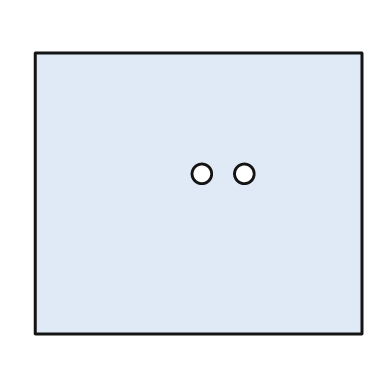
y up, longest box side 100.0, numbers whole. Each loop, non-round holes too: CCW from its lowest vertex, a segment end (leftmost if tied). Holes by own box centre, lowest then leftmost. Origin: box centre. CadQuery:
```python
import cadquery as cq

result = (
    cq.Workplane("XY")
    .moveTo(-50.0, -43.0)
    .lineTo(50.0, -43.0)
    .lineTo(50.0, 43.0)
    .lineTo(-50.0, 43.0)
    .close()
    .moveTo(1.0, 6.0)
    .circle(3.0)
    .moveTo(14.0, 6.0)
    .circle(3.0)
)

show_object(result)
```